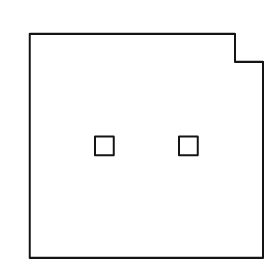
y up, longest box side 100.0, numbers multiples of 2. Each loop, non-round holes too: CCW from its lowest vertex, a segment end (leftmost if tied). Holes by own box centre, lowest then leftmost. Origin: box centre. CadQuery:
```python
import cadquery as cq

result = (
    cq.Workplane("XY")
    .moveTo(-50.0, -48.0)
    .lineTo(50.0, -48.0)
    .lineTo(50.0, 36.0)
    .lineTo(38.0, 36.0)
    .lineTo(38.0, 48.0)
    .lineTo(-50.0, 48.0)
    .close()
    .moveTo(-22.0, -4.0)
    .lineTo(-14.0, -4.0)
    .lineTo(-14.0, 4.0)
    .lineTo(-22.0, 4.0)
    .close()
    .moveTo(14.0, -4.0)
    .lineTo(22.0, -4.0)
    .lineTo(22.0, 4.0)
    .lineTo(14.0, 4.0)
    .close()
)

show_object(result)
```